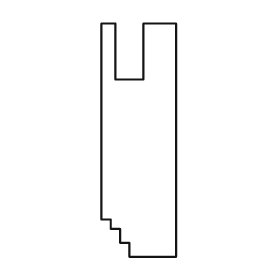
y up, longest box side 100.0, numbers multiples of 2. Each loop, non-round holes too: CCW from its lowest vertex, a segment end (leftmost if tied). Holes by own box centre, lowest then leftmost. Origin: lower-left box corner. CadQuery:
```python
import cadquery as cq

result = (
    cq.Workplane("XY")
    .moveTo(12.0, 0.0)
    .lineTo(32.0, 0.0)
    .lineTo(32.0, 100.0)
    .lineTo(18.0, 100.0)
    .lineTo(18.0, 76.0)
    .lineTo(6.0, 76.0)
    .lineTo(6.0, 100.0)
    .lineTo(0.0, 100.0)
    .lineTo(0.0, 16.0)
    .lineTo(4.0, 16.0)
    .lineTo(4.0, 12.0)
    .lineTo(8.0, 12.0)
    .lineTo(8.0, 6.0)
    .lineTo(12.0, 6.0)
    .close()
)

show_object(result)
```